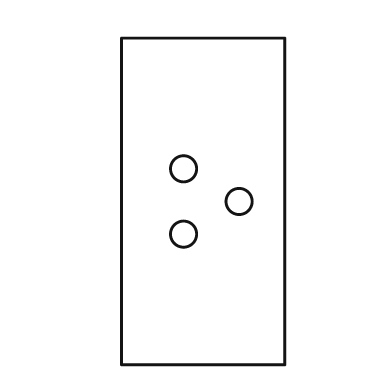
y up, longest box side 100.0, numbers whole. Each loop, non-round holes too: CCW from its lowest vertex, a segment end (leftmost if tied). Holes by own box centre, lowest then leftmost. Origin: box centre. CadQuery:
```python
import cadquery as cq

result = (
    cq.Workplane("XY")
    .moveTo(-25.0, -50.0)
    .lineTo(25.0, -50.0)
    .lineTo(25.0, 50.0)
    .lineTo(-25.0, 50.0)
    .close()
    .moveTo(-6.0, -10.0)
    .circle(4.0)
    .moveTo(11.0, 0.0)
    .circle(4.0)
    .moveTo(-6.0, 10.0)
    .circle(4.0)
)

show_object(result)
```